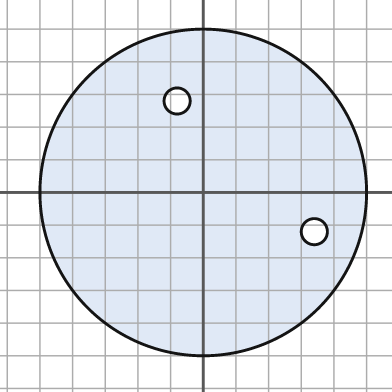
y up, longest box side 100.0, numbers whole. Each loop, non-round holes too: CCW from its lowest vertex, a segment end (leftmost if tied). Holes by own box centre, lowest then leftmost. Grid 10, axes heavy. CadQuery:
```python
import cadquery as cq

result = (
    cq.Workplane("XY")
    .moveTo(0.0, 0.0)
    .circle(50.0)
    .moveTo(34.0, -12.0)
    .circle(4.0)
    .moveTo(-8.0, 28.0)
    .circle(4.0)
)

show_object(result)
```